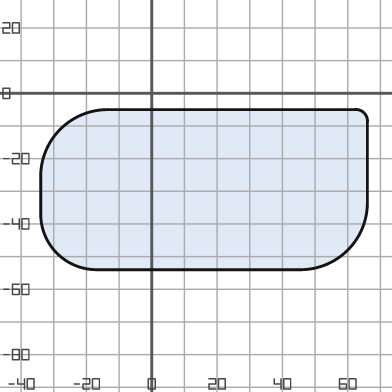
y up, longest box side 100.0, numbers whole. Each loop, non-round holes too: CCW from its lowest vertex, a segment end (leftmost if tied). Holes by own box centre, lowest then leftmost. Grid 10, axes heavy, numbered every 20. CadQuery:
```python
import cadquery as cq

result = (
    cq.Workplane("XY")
    .moveTo(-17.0, -54.0)
    .lineTo(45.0, -54.0)
    .threePointArc((60.0, -48.0), (66.0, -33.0))
    .lineTo(66.0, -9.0)
    .threePointArc((65.0, -6.0), (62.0, -5.0))
    .lineTo(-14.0, -5.0)
    .threePointArc((-28.0, -11.0), (-34.0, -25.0))
    .lineTo(-34.0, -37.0)
    .threePointArc((-29.0, -49.0), (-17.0, -54.0))
    .close()
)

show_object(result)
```